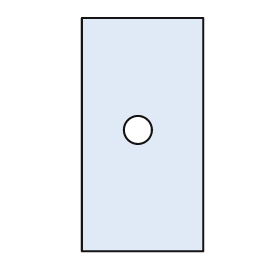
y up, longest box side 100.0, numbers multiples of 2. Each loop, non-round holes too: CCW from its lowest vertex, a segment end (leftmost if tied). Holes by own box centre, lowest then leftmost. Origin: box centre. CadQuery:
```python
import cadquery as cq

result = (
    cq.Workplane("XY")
    .moveTo(-26.0, -50.0)
    .lineTo(26.0, -50.0)
    .lineTo(26.0, 50.0)
    .lineTo(-26.0, 50.0)
    .close()
    .moveTo(-2.0, 2.0)
    .circle(6.0)
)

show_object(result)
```